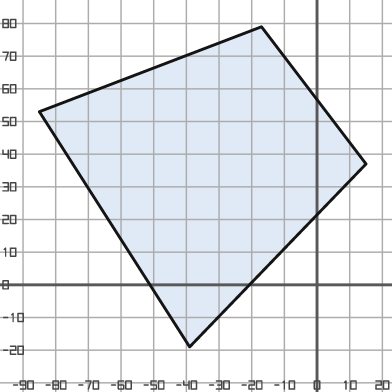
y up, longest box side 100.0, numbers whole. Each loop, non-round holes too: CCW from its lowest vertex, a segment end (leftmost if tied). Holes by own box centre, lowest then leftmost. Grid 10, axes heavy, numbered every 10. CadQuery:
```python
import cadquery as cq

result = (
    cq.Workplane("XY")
    .moveTo(-39.0, -19.0)
    .lineTo(15.0, 37.0)
    .lineTo(-17.0, 79.0)
    .lineTo(-85.0, 53.0)
    .close()
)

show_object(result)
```